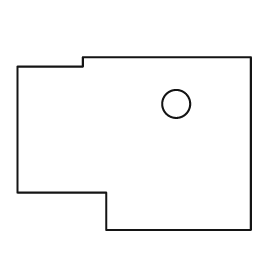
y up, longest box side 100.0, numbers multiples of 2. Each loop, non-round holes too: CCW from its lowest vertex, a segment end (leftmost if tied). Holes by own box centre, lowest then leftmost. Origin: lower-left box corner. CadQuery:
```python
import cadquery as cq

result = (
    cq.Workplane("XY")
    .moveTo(38.0, 0.0)
    .lineTo(100.0, 0.0)
    .lineTo(100.0, 74.0)
    .lineTo(28.0, 74.0)
    .lineTo(28.0, 70.0)
    .lineTo(0.0, 70.0)
    .lineTo(0.0, 16.0)
    .lineTo(38.0, 16.0)
    .close()
    .moveTo(68.0, 54.0)
    .circle(6.0)
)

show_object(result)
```